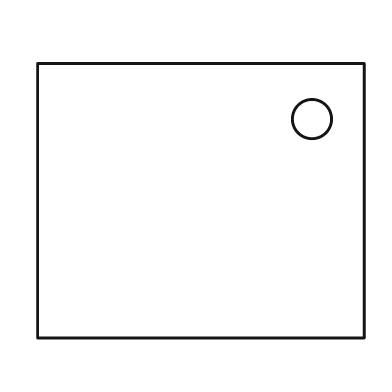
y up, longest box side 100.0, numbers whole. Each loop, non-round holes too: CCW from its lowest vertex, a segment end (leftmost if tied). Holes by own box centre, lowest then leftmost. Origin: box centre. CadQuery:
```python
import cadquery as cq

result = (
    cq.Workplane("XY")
    .moveTo(-50.0, -42.0)
    .lineTo(50.0, -42.0)
    .lineTo(50.0, 42.0)
    .lineTo(-50.0, 42.0)
    .close()
    .moveTo(34.0, 25.0)
    .circle(6.0)
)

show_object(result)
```